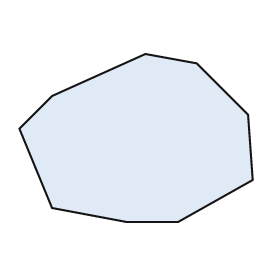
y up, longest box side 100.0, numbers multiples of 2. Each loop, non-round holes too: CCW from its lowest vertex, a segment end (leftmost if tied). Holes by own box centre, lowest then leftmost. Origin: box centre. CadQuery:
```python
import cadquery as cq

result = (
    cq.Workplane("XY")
    .moveTo(-4.0, -36.0)
    .lineTo(18.0, -36.0)
    .lineTo(50.0, -18.0)
    .lineTo(48.0, 10.0)
    .lineTo(26.0, 32.0)
    .lineTo(4.0, 36.0)
    .lineTo(-36.0, 18.0)
    .lineTo(-50.0, 4.0)
    .lineTo(-36.0, -30.0)
    .close()
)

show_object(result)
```